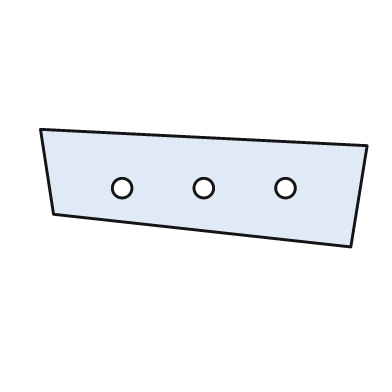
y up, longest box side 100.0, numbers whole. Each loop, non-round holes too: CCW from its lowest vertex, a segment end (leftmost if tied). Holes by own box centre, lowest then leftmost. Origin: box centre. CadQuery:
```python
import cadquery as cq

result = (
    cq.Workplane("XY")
    .moveTo(45.0, -18.0)
    .lineTo(50.0, 13.0)
    .lineTo(-50.0, 18.0)
    .lineTo(-46.0, -8.0)
    .close()
    .moveTo(-25.0, 0.0)
    .circle(3.0)
    .moveTo(0.0, 0.0)
    .circle(3.0)
    .moveTo(25.0, 0.0)
    .circle(3.0)
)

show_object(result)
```